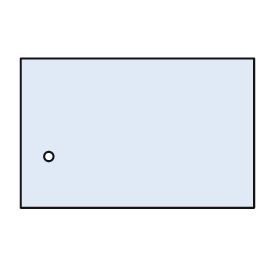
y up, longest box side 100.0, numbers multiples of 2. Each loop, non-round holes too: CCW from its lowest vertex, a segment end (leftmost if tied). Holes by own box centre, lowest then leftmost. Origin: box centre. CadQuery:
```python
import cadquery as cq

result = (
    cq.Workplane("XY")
    .moveTo(-50.0, -32.0)
    .lineTo(50.0, -32.0)
    .lineTo(50.0, 32.0)
    .lineTo(-50.0, 32.0)
    .close()
    .moveTo(-38.0, -10.0)
    .circle(2.0)
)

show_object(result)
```